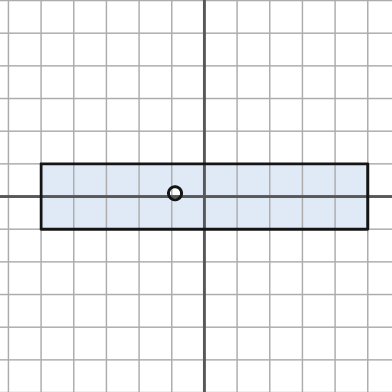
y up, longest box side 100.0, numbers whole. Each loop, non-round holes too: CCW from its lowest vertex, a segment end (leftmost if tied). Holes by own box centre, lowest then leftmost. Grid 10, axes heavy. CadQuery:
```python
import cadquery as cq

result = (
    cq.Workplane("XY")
    .moveTo(-50.0, -10.0)
    .lineTo(50.0, -10.0)
    .lineTo(50.0, 10.0)
    .lineTo(-50.0, 10.0)
    .close()
    .moveTo(-9.0, 1.0)
    .circle(2.0)
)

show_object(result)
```